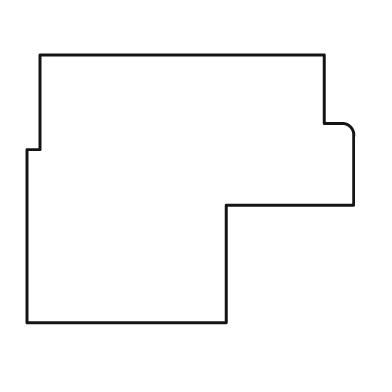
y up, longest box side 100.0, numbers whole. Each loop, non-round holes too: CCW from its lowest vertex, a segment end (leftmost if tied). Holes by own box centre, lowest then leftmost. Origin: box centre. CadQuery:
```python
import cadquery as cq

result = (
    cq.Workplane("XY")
    .moveTo(-50.0, -41.0)
    .lineTo(11.0, -41.0)
    .lineTo(11.0, -5.0)
    .lineTo(50.0, -5.0)
    .lineTo(50.0, 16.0)
    .threePointArc((49.0, 19.0), (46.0, 20.0))
    .lineTo(41.0, 20.0)
    .lineTo(41.0, 41.0)
    .lineTo(-46.0, 41.0)
    .lineTo(-46.0, 12.0)
    .lineTo(-50.0, 12.0)
    .close()
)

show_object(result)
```